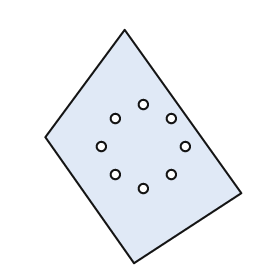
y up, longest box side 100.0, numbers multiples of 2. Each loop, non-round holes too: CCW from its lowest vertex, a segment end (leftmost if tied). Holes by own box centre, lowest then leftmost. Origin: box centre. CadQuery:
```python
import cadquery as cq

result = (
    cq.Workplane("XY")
    .moveTo(-4.0, -50.0)
    .lineTo(42.0, -20.0)
    .lineTo(-8.0, 50.0)
    .lineTo(-42.0, 4.0)
    .close()
    .moveTo(0.0, -18.0)
    .circle(2.0)
    .moveTo(-12.0, -12.0)
    .circle(2.0)
    .moveTo(12.0, -12.0)
    .circle(2.0)
    .moveTo(-18.0, 0.0)
    .circle(2.0)
    .moveTo(18.0, 0.0)
    .circle(2.0)
    .moveTo(-12.0, 12.0)
    .circle(2.0)
    .moveTo(12.0, 12.0)
    .circle(2.0)
    .moveTo(0.0, 18.0)
    .circle(2.0)
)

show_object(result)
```